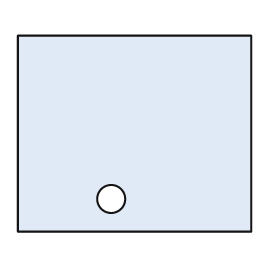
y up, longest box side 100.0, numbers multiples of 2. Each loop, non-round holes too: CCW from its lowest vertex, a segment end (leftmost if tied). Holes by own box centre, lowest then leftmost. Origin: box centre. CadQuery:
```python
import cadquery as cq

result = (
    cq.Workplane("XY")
    .moveTo(-50.0, -42.0)
    .lineTo(50.0, -42.0)
    .lineTo(50.0, 42.0)
    .lineTo(-50.0, 42.0)
    .close()
    .moveTo(-10.0, -28.0)
    .circle(6.0)
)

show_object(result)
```